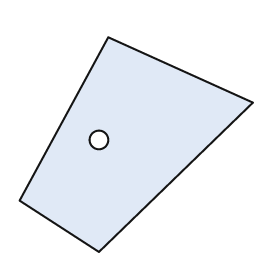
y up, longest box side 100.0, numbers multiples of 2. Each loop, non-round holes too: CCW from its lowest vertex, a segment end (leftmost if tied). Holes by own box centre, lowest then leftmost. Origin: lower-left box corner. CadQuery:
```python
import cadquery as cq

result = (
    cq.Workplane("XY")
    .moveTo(34.0, 0.0)
    .lineTo(100.0, 64.0)
    .lineTo(38.0, 92.0)
    .lineTo(0.0, 22.0)
    .close()
    .moveTo(34.0, 48.0)
    .circle(4.0)
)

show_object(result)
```